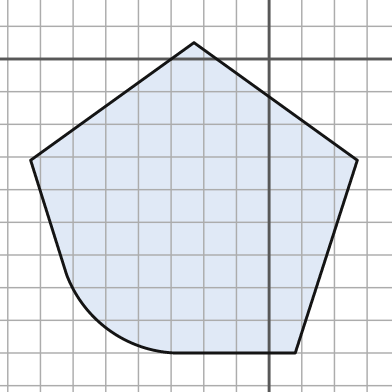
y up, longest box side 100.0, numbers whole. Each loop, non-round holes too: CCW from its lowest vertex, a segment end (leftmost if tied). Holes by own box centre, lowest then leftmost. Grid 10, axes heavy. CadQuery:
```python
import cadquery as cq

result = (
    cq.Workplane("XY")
    .moveTo(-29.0, -90.0)
    .lineTo(8.0, -90.0)
    .lineTo(27.0, -31.0)
    .lineTo(-23.0, 5.0)
    .lineTo(-73.0, -31.0)
    .lineTo(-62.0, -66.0)
    .threePointArc((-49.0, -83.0), (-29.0, -90.0))
    .close()
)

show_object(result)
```